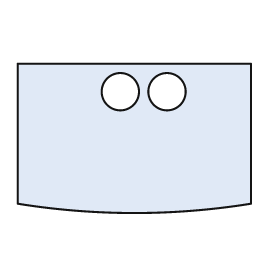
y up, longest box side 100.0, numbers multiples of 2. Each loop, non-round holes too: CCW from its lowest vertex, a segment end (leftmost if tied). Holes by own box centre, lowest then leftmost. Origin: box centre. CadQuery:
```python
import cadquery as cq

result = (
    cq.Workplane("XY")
    .moveTo(-50.0, -28.0)
    .threePointArc((0.0, -32.0), (50.0, -28.0))
    .lineTo(50.0, 32.0)
    .lineTo(-50.0, 32.0)
    .close()
    .moveTo(-6.0, 20.0)
    .circle(8.0)
    .moveTo(14.0, 20.0)
    .circle(8.0)
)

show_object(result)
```